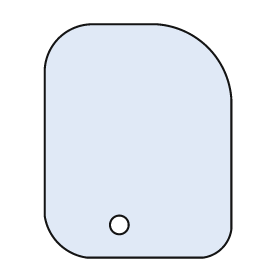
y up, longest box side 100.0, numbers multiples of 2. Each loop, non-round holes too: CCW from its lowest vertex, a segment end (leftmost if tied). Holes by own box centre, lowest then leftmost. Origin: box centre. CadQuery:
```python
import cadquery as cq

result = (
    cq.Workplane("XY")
    .moveTo(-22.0, -50.0)
    .lineTo(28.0, -50.0)
    .threePointArc((36.0, -46.0), (40.0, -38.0))
    .lineTo(40.0, 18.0)
    .threePointArc((30.0, 40.0), (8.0, 50.0))
    .lineTo(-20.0, 50.0)
    .threePointArc((-34.0, 44.0), (-40.0, 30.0))
    .lineTo(-40.0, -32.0)
    .threePointArc((-34.0, -44.0), (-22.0, -50.0))
    .close()
    .moveTo(-8.0, -36.0)
    .circle(4.0)
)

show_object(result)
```